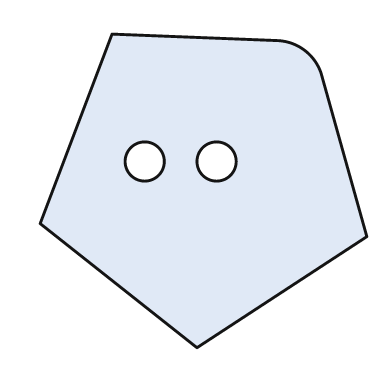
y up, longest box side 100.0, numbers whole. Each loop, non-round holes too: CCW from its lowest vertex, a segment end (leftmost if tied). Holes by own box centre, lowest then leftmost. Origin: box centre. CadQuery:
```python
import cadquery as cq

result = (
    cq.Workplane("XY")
    .moveTo(-2.0, -48.0)
    .lineTo(50.0, -14.0)
    .lineTo(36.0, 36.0)
    .threePointArc((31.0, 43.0), (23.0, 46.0))
    .lineTo(-28.0, 48.0)
    .lineTo(-50.0, -10.0)
    .close()
    .moveTo(-18.0, 9.0)
    .circle(6.0)
    .moveTo(4.0, 9.0)
    .circle(6.0)
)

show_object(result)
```